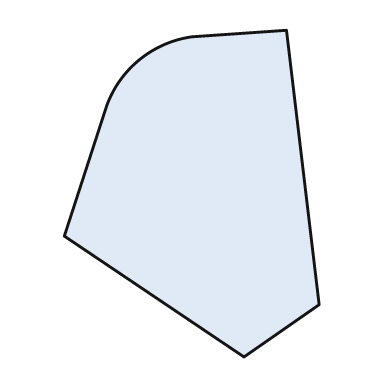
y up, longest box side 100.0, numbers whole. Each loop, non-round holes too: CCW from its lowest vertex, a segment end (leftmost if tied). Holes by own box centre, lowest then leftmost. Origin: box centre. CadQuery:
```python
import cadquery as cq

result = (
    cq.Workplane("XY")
    .moveTo(16.0, -50.0)
    .lineTo(39.0, -34.0)
    .lineTo(29.0, 50.0)
    .lineTo(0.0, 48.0)
    .threePointArc((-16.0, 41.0), (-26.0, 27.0))
    .lineTo(-39.0, -13.0)
    .close()
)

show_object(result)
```